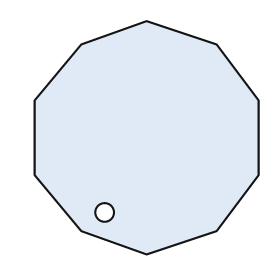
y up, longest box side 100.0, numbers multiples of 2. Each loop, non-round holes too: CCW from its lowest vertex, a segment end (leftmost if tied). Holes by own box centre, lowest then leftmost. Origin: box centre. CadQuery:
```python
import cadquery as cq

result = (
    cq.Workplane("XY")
    .moveTo(0.0, -50.0)
    .lineTo(30.0, -40.0)
    .lineTo(48.0, -16.0)
    .lineTo(48.0, 16.0)
    .lineTo(30.0, 40.0)
    .lineTo(0.0, 50.0)
    .lineTo(-28.0, 40.0)
    .lineTo(-48.0, 16.0)
    .lineTo(-48.0, -16.0)
    .lineTo(-28.0, -40.0)
    .close()
    .moveTo(-18.0, -32.0)
    .circle(4.0)
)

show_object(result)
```